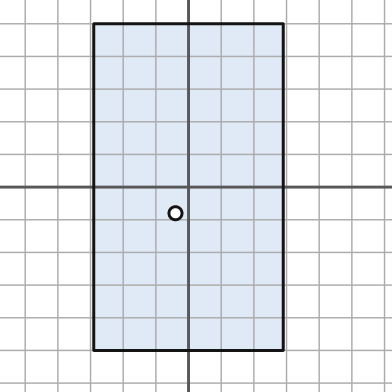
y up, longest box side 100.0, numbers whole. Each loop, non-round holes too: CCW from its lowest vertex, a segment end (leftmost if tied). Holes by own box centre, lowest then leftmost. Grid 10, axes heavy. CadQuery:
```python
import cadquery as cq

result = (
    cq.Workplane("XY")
    .moveTo(-29.0, -50.0)
    .lineTo(29.0, -50.0)
    .lineTo(29.0, 50.0)
    .lineTo(-29.0, 50.0)
    .close()
    .moveTo(-4.0, -8.0)
    .circle(2.0)
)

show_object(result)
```